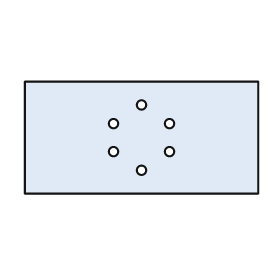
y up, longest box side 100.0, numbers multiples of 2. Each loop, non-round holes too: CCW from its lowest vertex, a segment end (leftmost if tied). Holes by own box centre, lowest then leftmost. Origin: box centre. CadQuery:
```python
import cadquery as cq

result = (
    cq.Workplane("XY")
    .moveTo(-50.0, -24.0)
    .lineTo(50.0, -24.0)
    .lineTo(50.0, 24.0)
    .lineTo(-50.0, 24.0)
    .close()
    .moveTo(0.0, -14.0)
    .circle(2.0)
    .moveTo(-12.0, -6.0)
    .circle(2.0)
    .moveTo(12.0, -6.0)
    .circle(2.0)
    .moveTo(-12.0, 6.0)
    .circle(2.0)
    .moveTo(12.0, 6.0)
    .circle(2.0)
    .moveTo(0.0, 14.0)
    .circle(2.0)
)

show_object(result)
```